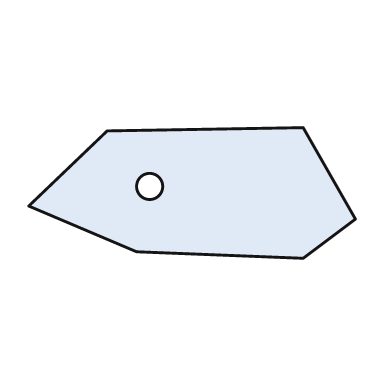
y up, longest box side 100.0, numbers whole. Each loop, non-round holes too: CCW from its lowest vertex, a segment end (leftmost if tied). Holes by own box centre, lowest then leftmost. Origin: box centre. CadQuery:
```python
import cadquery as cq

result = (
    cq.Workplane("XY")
    .moveTo(34.0, -20.0)
    .lineTo(50.0, -8.0)
    .lineTo(34.0, 20.0)
    .lineTo(-26.0, 19.0)
    .lineTo(-50.0, -4.0)
    .lineTo(-17.0, -18.0)
    .close()
    .moveTo(-13.0, 2.0)
    .circle(4.0)
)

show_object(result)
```